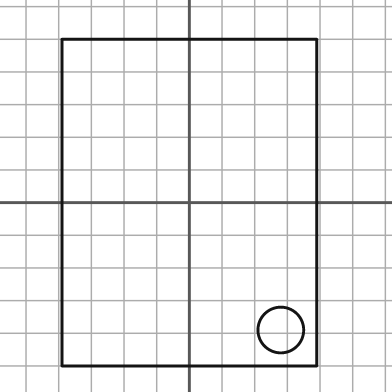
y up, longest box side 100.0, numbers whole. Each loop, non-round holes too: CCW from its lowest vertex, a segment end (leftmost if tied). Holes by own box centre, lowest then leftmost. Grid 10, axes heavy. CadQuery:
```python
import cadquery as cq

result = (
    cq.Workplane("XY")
    .moveTo(-39.0, -50.0)
    .lineTo(39.0, -50.0)
    .lineTo(39.0, 50.0)
    .lineTo(-39.0, 50.0)
    .close()
    .moveTo(28.0, -39.0)
    .circle(7.0)
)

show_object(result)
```